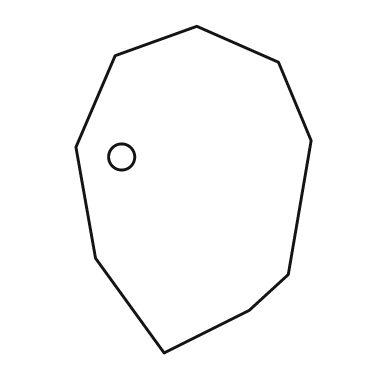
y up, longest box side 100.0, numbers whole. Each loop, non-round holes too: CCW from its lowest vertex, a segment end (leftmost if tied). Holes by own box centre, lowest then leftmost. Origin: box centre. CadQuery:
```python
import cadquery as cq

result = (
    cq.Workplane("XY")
    .moveTo(-9.0, -50.0)
    .lineTo(17.0, -37.0)
    .lineTo(29.0, -26.0)
    .lineTo(36.0, 15.0)
    .lineTo(26.0, 39.0)
    .lineTo(1.0, 50.0)
    .lineTo(-24.0, 41.0)
    .lineTo(-36.0, 13.0)
    .lineTo(-30.0, -21.0)
    .close()
    .moveTo(-22.0, 10.0)
    .circle(4.0)
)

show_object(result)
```